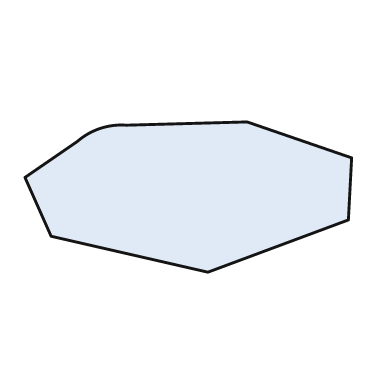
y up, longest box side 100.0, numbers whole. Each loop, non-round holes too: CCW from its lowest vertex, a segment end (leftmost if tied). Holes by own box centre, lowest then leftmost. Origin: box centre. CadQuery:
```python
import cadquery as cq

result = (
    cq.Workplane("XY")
    .moveTo(6.0, -23.0)
    .lineTo(49.0, -7.0)
    .lineTo(50.0, 12.0)
    .lineTo(18.0, 23.0)
    .lineTo(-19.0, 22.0)
    .threePointArc((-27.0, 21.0), (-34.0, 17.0))
    .lineTo(-50.0, 6.0)
    .lineTo(-42.0, -12.0)
    .close()
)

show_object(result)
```